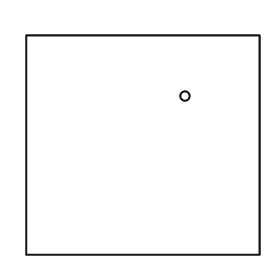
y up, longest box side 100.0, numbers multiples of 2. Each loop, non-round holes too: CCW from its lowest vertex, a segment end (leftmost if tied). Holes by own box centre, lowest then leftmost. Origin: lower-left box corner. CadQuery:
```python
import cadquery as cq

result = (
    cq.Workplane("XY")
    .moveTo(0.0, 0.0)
    .lineTo(100.0, 0.0)
    .lineTo(100.0, 94.0)
    .lineTo(0.0, 94.0)
    .close()
    .moveTo(68.0, 68.0)
    .circle(2.0)
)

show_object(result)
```